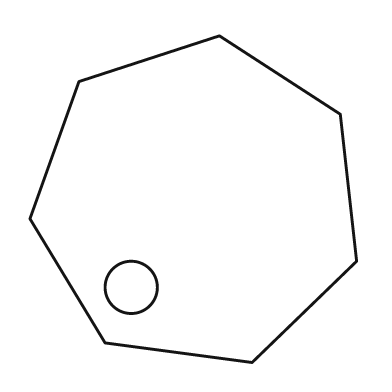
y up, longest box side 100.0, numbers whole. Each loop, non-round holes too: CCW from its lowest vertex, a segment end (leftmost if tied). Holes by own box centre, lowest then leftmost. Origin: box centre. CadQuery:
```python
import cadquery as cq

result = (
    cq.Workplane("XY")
    .moveTo(18.0, -50.0)
    .lineTo(50.0, -19.0)
    .lineTo(45.0, 26.0)
    .lineTo(8.0, 50.0)
    .lineTo(-35.0, 36.0)
    .lineTo(-50.0, -6.0)
    .lineTo(-27.0, -44.0)
    .close()
    .moveTo(-19.0, -27.0)
    .circle(8.0)
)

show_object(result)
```